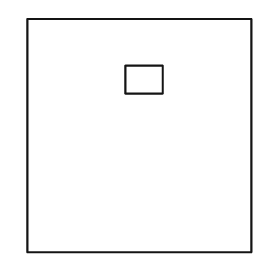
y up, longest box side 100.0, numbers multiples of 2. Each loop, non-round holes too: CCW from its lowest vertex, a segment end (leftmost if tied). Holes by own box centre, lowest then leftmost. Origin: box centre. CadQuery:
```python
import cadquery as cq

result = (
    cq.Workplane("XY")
    .moveTo(-48.0, -50.0)
    .lineTo(48.0, -50.0)
    .lineTo(48.0, 50.0)
    .lineTo(-48.0, 50.0)
    .close()
    .moveTo(-6.0, 18.0)
    .lineTo(10.0, 18.0)
    .lineTo(10.0, 30.0)
    .lineTo(-6.0, 30.0)
    .close()
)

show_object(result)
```